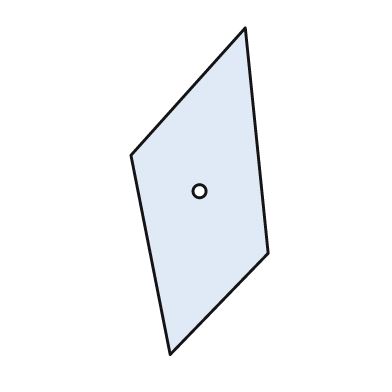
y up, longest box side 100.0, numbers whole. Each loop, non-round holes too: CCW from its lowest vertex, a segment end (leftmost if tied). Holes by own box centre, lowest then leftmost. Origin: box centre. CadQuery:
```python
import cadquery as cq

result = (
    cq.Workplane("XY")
    .moveTo(-9.0, -50.0)
    .lineTo(21.0, -19.0)
    .lineTo(14.0, 50.0)
    .lineTo(-21.0, 11.0)
    .close()
    .moveTo(0.0, 0.0)
    .circle(2.0)
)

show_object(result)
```